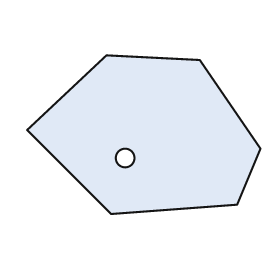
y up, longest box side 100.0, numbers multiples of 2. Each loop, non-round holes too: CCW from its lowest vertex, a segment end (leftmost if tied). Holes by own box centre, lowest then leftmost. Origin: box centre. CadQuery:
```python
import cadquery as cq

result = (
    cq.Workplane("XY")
    .moveTo(-14.0, -34.0)
    .lineTo(40.0, -30.0)
    .lineTo(50.0, -6.0)
    .lineTo(24.0, 32.0)
    .lineTo(-16.0, 34.0)
    .lineTo(-50.0, 2.0)
    .close()
    .moveTo(-8.0, -10.0)
    .circle(4.0)
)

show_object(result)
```